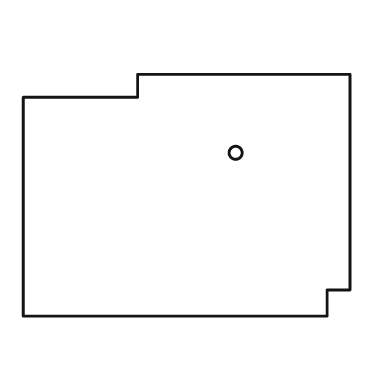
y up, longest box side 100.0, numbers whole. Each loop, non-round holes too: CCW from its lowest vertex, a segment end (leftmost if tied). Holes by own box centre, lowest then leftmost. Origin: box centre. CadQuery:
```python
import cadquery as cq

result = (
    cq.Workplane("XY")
    .moveTo(-50.0, -37.0)
    .lineTo(43.0, -37.0)
    .lineTo(43.0, -29.0)
    .lineTo(50.0, -29.0)
    .lineTo(50.0, 37.0)
    .lineTo(-15.0, 37.0)
    .lineTo(-15.0, 30.0)
    .lineTo(-50.0, 30.0)
    .close()
    .moveTo(15.0, 13.0)
    .circle(2.0)
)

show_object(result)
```